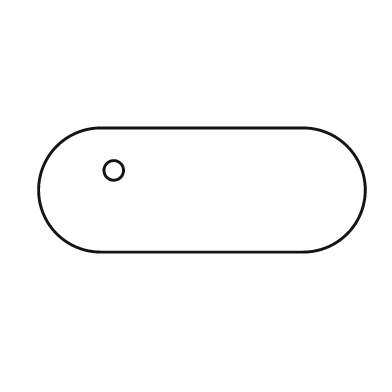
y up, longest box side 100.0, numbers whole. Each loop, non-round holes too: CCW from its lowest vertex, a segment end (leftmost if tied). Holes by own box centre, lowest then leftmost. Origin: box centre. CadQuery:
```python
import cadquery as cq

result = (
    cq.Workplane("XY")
    .moveTo(-31.0, -19.0)
    .lineTo(31.0, -19.0)
    .threePointArc((50.0, 0.0), (31.0, 19.0))
    .lineTo(-31.0, 19.0)
    .threePointArc((-50.0, 0.0), (-31.0, -19.0))
    .close()
    .moveTo(-27.0, 6.0)
    .circle(3.0)
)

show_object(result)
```